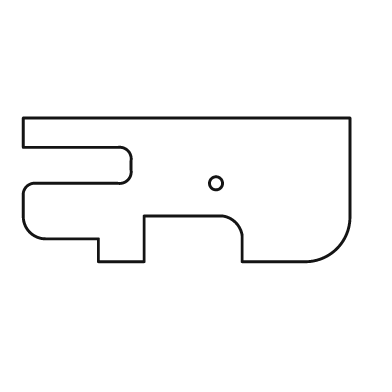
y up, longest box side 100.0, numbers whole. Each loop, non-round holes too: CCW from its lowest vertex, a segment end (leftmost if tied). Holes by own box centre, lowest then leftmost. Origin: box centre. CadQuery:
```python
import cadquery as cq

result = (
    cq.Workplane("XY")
    .moveTo(-27.0, -22.0)
    .lineTo(-13.0, -22.0)
    .lineTo(-13.0, -8.0)
    .lineTo(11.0, -8.0)
    .threePointArc((15.0, -10.0), (17.0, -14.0))
    .lineTo(17.0, -22.0)
    .lineTo(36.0, -22.0)
    .threePointArc((46.0, -18.0), (50.0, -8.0))
    .lineTo(50.0, 22.0)
    .lineTo(-50.0, 22.0)
    .lineTo(-50.0, 13.0)
    .lineTo(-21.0, 13.0)
    .threePointArc((-18.0, 12.0), (-17.0, 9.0))
    .lineTo(-17.0, 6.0)
    .threePointArc((-18.0, 3.0), (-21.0, 2.0))
    .lineTo(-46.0, 2.0)
    .threePointArc((-49.0, 1.0), (-50.0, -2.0))
    .lineTo(-50.0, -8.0)
    .threePointArc((-48.0, -13.0), (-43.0, -15.0))
    .lineTo(-27.0, -15.0)
    .close()
    .moveTo(9.0, 2.0)
    .circle(2.0)
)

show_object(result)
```